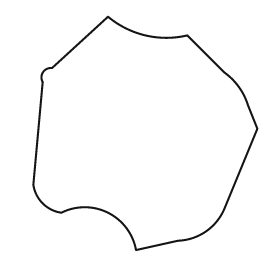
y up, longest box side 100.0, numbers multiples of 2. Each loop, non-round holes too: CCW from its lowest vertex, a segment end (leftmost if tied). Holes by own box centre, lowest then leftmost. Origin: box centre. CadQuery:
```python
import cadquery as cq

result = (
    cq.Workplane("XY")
    .moveTo(-4.0, -50.0)
    .lineTo(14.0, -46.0)
    .threePointArc((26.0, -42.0), (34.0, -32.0))
    .lineTo(48.0, 2.0)
    .lineTo(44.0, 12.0)
    .threePointArc((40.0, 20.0), (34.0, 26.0))
    .lineTo(18.0, 42.0)
    .threePointArc((0.0, 42.0), (-16.0, 50.0))
    .lineTo(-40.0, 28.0)
    .threePointArc((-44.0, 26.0), (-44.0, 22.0))
    .lineTo(-48.0, -22.0)
    .threePointArc((-44.0, -30.0), (-36.0, -34.0))
    .threePointArc((-16.0, -34.0), (-4.0, -50.0))
    .close()
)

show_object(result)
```